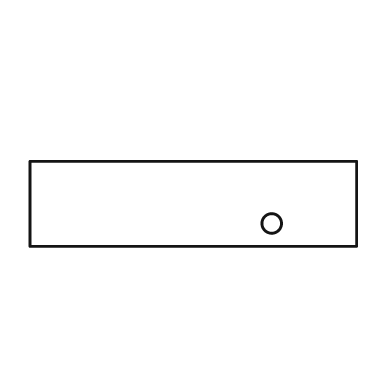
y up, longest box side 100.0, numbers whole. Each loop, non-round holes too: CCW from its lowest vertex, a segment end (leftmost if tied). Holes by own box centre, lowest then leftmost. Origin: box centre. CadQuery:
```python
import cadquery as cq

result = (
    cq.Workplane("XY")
    .moveTo(-50.0, -13.0)
    .lineTo(50.0, -13.0)
    .lineTo(50.0, 13.0)
    .lineTo(-50.0, 13.0)
    .close()
    .moveTo(24.0, -6.0)
    .circle(3.0)
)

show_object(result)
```